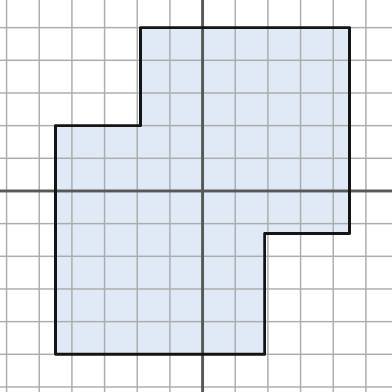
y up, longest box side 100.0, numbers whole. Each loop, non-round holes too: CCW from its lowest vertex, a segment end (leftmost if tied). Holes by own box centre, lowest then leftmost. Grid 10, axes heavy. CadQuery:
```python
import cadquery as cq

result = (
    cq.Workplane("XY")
    .moveTo(-45.0, -50.0)
    .lineTo(19.0, -50.0)
    .lineTo(19.0, -13.0)
    .lineTo(45.0, -13.0)
    .lineTo(45.0, 50.0)
    .lineTo(-19.0, 50.0)
    .lineTo(-19.0, 20.0)
    .lineTo(-45.0, 20.0)
    .close()
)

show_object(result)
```